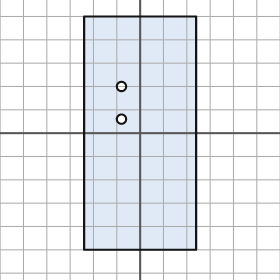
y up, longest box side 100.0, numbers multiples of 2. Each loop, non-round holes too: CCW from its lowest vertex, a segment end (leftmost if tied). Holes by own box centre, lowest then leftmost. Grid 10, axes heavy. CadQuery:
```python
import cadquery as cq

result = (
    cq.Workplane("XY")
    .moveTo(-24.0, -50.0)
    .lineTo(24.0, -50.0)
    .lineTo(24.0, 50.0)
    .lineTo(-24.0, 50.0)
    .close()
    .moveTo(-8.0, 6.0)
    .circle(2.0)
    .moveTo(-8.0, 20.0)
    .circle(2.0)
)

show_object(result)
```